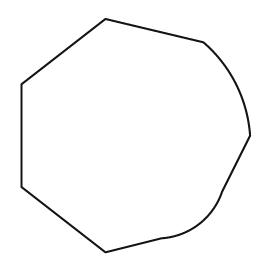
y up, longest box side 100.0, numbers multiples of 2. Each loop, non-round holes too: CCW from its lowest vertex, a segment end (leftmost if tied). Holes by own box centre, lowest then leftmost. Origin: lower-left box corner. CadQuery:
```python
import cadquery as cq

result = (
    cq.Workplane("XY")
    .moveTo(36.0, 0.0)
    .lineTo(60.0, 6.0)
    .threePointArc((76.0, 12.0), (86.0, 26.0))
    .lineTo(98.0, 50.0)
    .threePointArc((92.0, 72.0), (78.0, 90.0))
    .lineTo(36.0, 100.0)
    .lineTo(0.0, 72.0)
    .lineTo(0.0, 28.0)
    .close()
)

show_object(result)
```